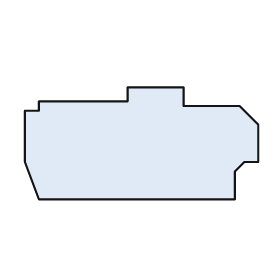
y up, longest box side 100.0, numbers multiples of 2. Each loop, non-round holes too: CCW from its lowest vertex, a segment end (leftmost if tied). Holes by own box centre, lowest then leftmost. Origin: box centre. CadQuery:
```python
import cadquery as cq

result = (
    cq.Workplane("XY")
    .moveTo(-44.0, -24.0)
    .lineTo(40.0, -24.0)
    .lineTo(40.0, -12.0)
    .lineTo(44.0, -8.0)
    .lineTo(50.0, -8.0)
    .lineTo(50.0, 8.0)
    .lineTo(42.0, 16.0)
    .lineTo(18.0, 16.0)
    .lineTo(18.0, 24.0)
    .lineTo(-6.0, 24.0)
    .lineTo(-6.0, 18.0)
    .lineTo(-44.0, 18.0)
    .lineTo(-44.0, 14.0)
    .lineTo(-50.0, 14.0)
    .lineTo(-50.0, -8.0)
    .close()
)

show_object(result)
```